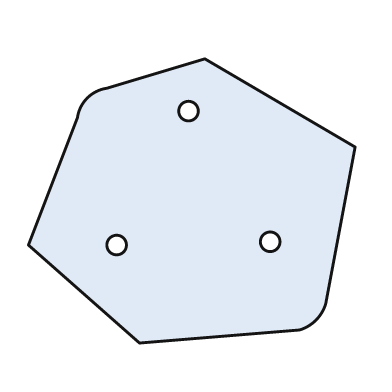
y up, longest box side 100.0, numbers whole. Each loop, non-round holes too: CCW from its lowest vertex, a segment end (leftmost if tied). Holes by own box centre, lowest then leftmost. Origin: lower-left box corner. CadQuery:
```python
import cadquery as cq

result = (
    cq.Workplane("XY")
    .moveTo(34.0, 0.0)
    .lineTo(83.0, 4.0)
    .threePointArc((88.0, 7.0), (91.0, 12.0))
    .lineTo(100.0, 60.0)
    .lineTo(54.0, 87.0)
    .lineTo(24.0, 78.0)
    .threePointArc((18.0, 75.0), (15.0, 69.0))
    .lineTo(0.0, 30.0)
    .close()
    .moveTo(27.0, 30.0)
    .circle(3.0)
    .moveTo(74.0, 31.0)
    .circle(3.0)
    .moveTo(49.0, 71.0)
    .circle(3.0)
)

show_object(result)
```